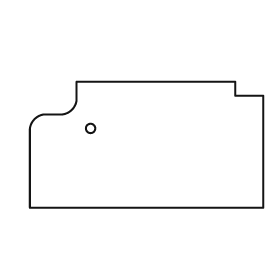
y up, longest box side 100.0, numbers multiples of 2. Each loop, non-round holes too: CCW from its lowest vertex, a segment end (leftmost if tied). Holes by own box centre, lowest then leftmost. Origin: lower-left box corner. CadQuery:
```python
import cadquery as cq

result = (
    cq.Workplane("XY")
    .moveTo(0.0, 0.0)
    .lineTo(100.0, 0.0)
    .lineTo(100.0, 48.0)
    .lineTo(88.0, 48.0)
    .lineTo(88.0, 54.0)
    .lineTo(20.0, 54.0)
    .lineTo(20.0, 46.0)
    .threePointArc((18.0, 42.0), (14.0, 40.0))
    .lineTo(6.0, 40.0)
    .threePointArc((2.0, 38.0), (0.0, 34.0))
    .close()
    .moveTo(26.0, 34.0)
    .circle(2.0)
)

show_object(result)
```